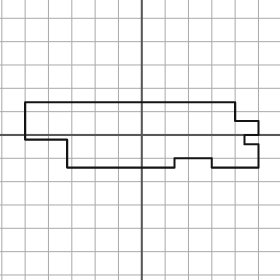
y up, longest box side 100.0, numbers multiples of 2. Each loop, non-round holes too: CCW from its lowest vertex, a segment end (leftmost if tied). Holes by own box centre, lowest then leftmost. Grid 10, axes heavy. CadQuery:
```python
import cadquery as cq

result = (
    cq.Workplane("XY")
    .moveTo(-32.0, -14.0)
    .lineTo(14.0, -14.0)
    .lineTo(14.0, -10.0)
    .lineTo(30.0, -10.0)
    .lineTo(30.0, -14.0)
    .lineTo(50.0, -14.0)
    .lineTo(50.0, -4.0)
    .lineTo(44.0, -4.0)
    .lineTo(44.0, 0.0)
    .lineTo(50.0, 0.0)
    .lineTo(50.0, 6.0)
    .lineTo(40.0, 6.0)
    .lineTo(40.0, 14.0)
    .lineTo(-50.0, 14.0)
    .lineTo(-50.0, -2.0)
    .lineTo(-32.0, -2.0)
    .close()
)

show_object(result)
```